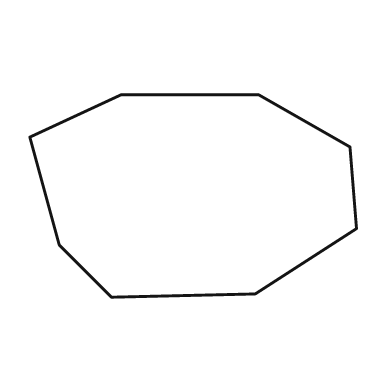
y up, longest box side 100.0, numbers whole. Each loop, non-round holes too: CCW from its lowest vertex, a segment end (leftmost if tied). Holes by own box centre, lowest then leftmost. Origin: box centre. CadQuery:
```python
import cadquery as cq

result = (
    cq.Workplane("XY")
    .moveTo(-25.0, -31.0)
    .lineTo(19.0, -30.0)
    .lineTo(50.0, -10.0)
    .lineTo(48.0, 15.0)
    .lineTo(20.0, 31.0)
    .lineTo(-22.0, 31.0)
    .lineTo(-50.0, 18.0)
    .lineTo(-41.0, -15.0)
    .close()
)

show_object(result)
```